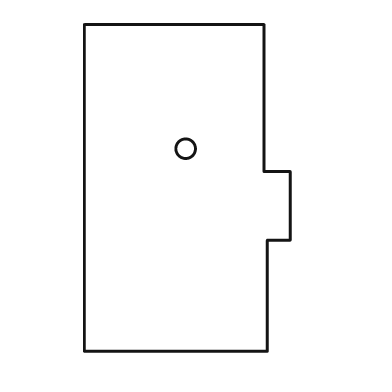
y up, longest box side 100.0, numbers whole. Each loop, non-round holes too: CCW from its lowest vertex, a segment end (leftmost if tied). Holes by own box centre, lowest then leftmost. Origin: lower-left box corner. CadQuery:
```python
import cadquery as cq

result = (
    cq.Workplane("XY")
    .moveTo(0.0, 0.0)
    .lineTo(56.0, 0.0)
    .lineTo(56.0, 34.0)
    .lineTo(63.0, 34.0)
    .lineTo(63.0, 55.0)
    .lineTo(55.0, 55.0)
    .lineTo(55.0, 100.0)
    .lineTo(0.0, 100.0)
    .close()
    .moveTo(31.0, 62.0)
    .circle(3.0)
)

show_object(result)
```